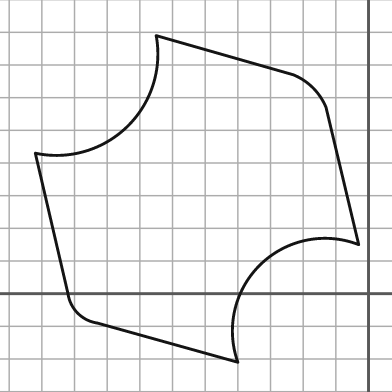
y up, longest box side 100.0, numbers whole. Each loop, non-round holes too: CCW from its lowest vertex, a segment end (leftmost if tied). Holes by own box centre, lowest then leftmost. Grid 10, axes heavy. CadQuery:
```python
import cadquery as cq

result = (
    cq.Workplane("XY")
    .moveTo(-40.0, -21.0)
    .threePointArc((-33.0, 9.0), (-3.0, 15.0))
    .lineTo(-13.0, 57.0)
    .threePointArc((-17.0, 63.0), (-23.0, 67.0))
    .lineTo(-65.0, 79.0)
    .threePointArc((-74.0, 51.0), (-102.0, 43.0))
    .lineTo(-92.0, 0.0)
    .threePointArc((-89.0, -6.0), (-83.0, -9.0))
    .close()
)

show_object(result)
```